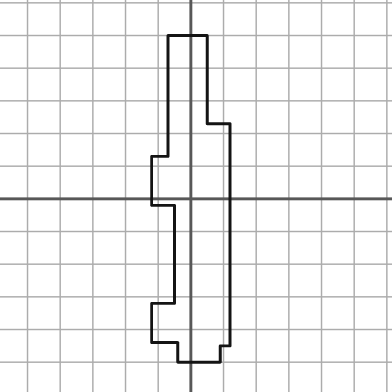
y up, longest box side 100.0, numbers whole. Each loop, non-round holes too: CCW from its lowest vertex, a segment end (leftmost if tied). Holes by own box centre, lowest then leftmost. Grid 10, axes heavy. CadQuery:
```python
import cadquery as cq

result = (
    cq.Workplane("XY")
    .moveTo(-4.0, -50.0)
    .lineTo(9.0, -50.0)
    .lineTo(9.0, -45.0)
    .lineTo(12.0, -45.0)
    .lineTo(12.0, 23.0)
    .lineTo(5.0, 23.0)
    .lineTo(5.0, 50.0)
    .lineTo(-7.0, 50.0)
    .lineTo(-7.0, 13.0)
    .lineTo(-12.0, 13.0)
    .lineTo(-12.0, -2.0)
    .lineTo(-5.0, -2.0)
    .lineTo(-5.0, -32.0)
    .lineTo(-12.0, -32.0)
    .lineTo(-12.0, -44.0)
    .lineTo(-4.0, -44.0)
    .close()
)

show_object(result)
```